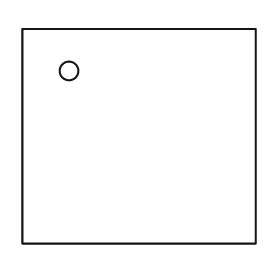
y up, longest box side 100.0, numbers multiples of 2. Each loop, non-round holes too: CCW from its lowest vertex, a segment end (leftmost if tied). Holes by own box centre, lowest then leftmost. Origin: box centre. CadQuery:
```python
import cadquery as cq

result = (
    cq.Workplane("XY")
    .moveTo(-50.0, -46.0)
    .lineTo(50.0, -46.0)
    .lineTo(50.0, 46.0)
    .lineTo(-50.0, 46.0)
    .close()
    .moveTo(-30.0, 28.0)
    .circle(4.0)
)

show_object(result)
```